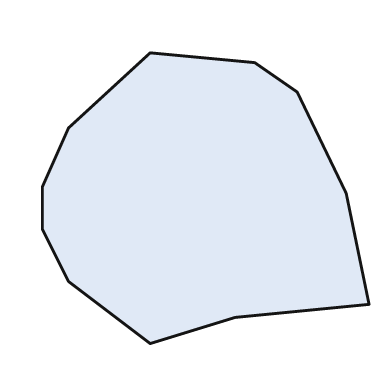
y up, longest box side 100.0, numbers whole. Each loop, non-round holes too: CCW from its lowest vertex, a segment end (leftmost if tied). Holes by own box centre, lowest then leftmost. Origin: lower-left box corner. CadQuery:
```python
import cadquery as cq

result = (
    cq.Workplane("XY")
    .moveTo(33.0, 0.0)
    .lineTo(59.0, 8.0)
    .lineTo(100.0, 12.0)
    .lineTo(93.0, 46.0)
    .lineTo(78.0, 77.0)
    .lineTo(65.0, 86.0)
    .lineTo(33.0, 89.0)
    .lineTo(8.0, 66.0)
    .lineTo(0.0, 48.0)
    .lineTo(0.0, 35.0)
    .lineTo(8.0, 19.0)
    .close()
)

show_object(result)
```